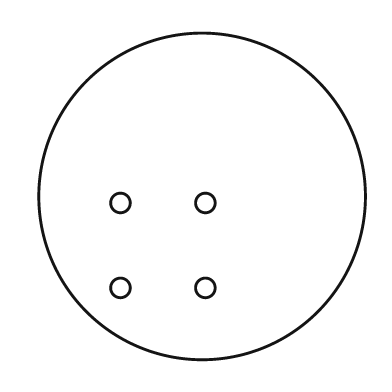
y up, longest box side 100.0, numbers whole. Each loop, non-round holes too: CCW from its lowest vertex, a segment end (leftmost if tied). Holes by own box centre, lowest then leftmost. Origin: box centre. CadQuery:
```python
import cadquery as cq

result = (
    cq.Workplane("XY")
    .moveTo(0.0, 0.0)
    .circle(50.0)
    .moveTo(-25.0, -28.0)
    .circle(3.0)
    .moveTo(1.0, -28.0)
    .circle(3.0)
    .moveTo(-25.0, -2.0)
    .circle(3.0)
    .moveTo(1.0, -2.0)
    .circle(3.0)
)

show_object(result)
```